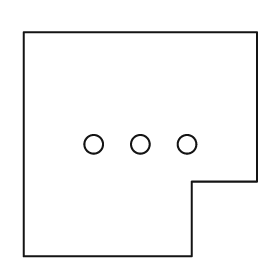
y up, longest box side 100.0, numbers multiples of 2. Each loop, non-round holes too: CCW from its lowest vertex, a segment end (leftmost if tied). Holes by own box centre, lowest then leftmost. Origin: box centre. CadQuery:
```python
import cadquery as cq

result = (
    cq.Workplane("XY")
    .moveTo(-50.0, -48.0)
    .lineTo(22.0, -48.0)
    .lineTo(22.0, -16.0)
    .lineTo(50.0, -16.0)
    .lineTo(50.0, 48.0)
    .lineTo(-50.0, 48.0)
    .close()
    .moveTo(-20.0, 0.0)
    .circle(4.0)
    .moveTo(0.0, 0.0)
    .circle(4.0)
    .moveTo(20.0, 0.0)
    .circle(4.0)
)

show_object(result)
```